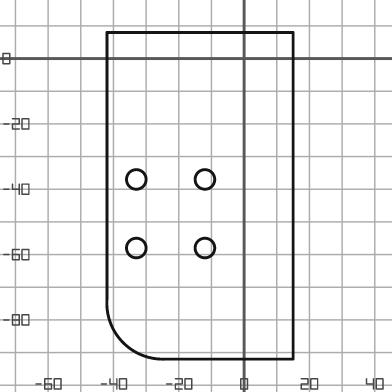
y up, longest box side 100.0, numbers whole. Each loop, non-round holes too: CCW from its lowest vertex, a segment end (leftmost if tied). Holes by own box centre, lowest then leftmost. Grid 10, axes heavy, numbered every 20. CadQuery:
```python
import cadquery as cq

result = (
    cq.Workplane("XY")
    .moveTo(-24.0, -92.0)
    .lineTo(15.0, -92.0)
    .lineTo(15.0, 8.0)
    .lineTo(-42.0, 8.0)
    .lineTo(-42.0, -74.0)
    .threePointArc((-37.0, -87.0), (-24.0, -92.0))
    .close()
    .moveTo(-33.0, -58.0)
    .circle(3.0)
    .moveTo(-12.0, -58.0)
    .circle(3.0)
    .moveTo(-33.0, -37.0)
    .circle(3.0)
    .moveTo(-12.0, -37.0)
    .circle(3.0)
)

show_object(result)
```